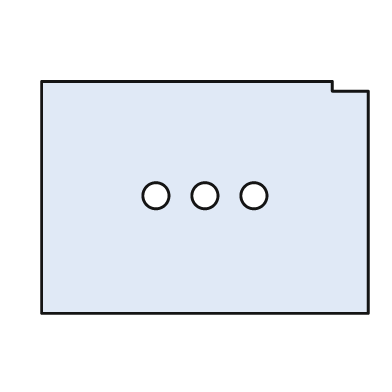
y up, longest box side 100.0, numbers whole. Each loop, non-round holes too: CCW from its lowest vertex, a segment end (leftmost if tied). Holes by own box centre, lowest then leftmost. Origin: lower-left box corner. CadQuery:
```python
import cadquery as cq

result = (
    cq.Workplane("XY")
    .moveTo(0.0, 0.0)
    .lineTo(100.0, 0.0)
    .lineTo(100.0, 68.0)
    .lineTo(89.0, 68.0)
    .lineTo(89.0, 71.0)
    .lineTo(0.0, 71.0)
    .close()
    .moveTo(35.0, 36.0)
    .circle(4.0)
    .moveTo(50.0, 36.0)
    .circle(4.0)
    .moveTo(65.0, 36.0)
    .circle(4.0)
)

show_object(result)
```